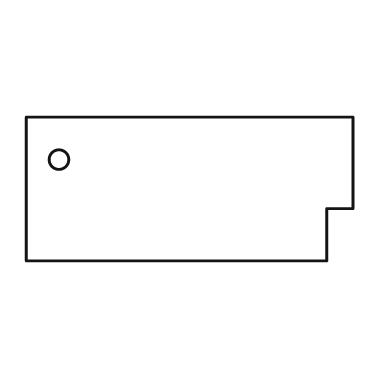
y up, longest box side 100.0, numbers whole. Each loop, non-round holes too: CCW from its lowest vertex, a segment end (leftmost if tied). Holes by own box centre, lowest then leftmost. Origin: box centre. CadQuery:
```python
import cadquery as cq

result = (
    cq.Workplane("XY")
    .moveTo(-50.0, -22.0)
    .lineTo(42.0, -22.0)
    .lineTo(42.0, -6.0)
    .lineTo(50.0, -6.0)
    .lineTo(50.0, 22.0)
    .lineTo(-50.0, 22.0)
    .close()
    .moveTo(-40.0, 9.0)
    .circle(3.0)
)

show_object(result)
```